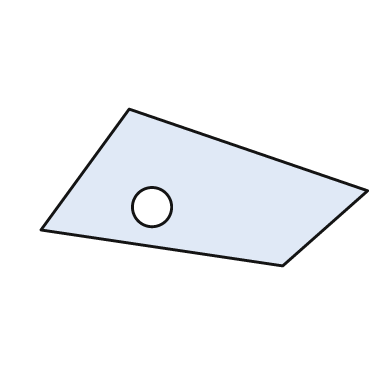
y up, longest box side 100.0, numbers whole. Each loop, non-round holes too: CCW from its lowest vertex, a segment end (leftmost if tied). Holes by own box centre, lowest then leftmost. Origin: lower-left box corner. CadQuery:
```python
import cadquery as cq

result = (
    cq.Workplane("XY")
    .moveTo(74.0, 0.0)
    .lineTo(100.0, 23.0)
    .lineTo(27.0, 48.0)
    .lineTo(0.0, 11.0)
    .close()
    .moveTo(34.0, 18.0)
    .circle(6.0)
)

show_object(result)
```